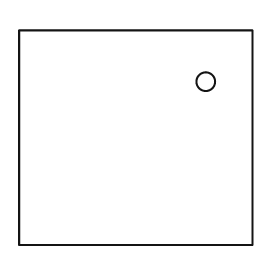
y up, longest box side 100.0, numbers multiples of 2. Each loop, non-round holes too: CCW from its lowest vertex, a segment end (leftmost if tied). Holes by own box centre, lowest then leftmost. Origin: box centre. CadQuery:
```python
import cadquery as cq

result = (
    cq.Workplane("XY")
    .moveTo(-50.0, -46.0)
    .lineTo(50.0, -46.0)
    .lineTo(50.0, 46.0)
    .lineTo(-50.0, 46.0)
    .close()
    .moveTo(30.0, 24.0)
    .circle(4.0)
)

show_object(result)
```